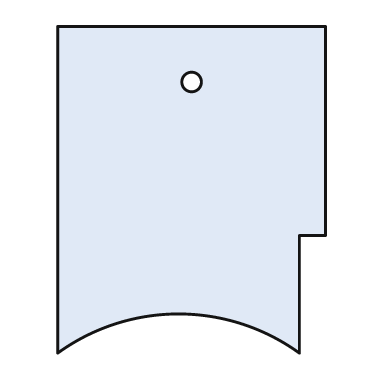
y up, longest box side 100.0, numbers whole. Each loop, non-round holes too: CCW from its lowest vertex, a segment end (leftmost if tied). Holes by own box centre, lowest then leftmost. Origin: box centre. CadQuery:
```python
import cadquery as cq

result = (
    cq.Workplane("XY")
    .moveTo(-41.0, -50.0)
    .threePointArc((-4.0, -38.0), (33.0, -50.0))
    .lineTo(33.0, -14.0)
    .lineTo(41.0, -14.0)
    .lineTo(41.0, 50.0)
    .lineTo(-41.0, 50.0)
    .close()
    .moveTo(0.0, 33.0)
    .circle(3.0)
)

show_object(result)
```